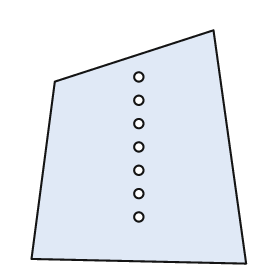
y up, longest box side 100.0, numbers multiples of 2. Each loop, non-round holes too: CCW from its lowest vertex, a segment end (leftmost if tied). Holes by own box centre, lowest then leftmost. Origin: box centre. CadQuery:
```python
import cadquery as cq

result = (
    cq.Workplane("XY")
    .moveTo(46.0, -50.0)
    .lineTo(32.0, 50.0)
    .lineTo(-36.0, 28.0)
    .lineTo(-46.0, -48.0)
    .close()
    .moveTo(0.0, -30.0)
    .circle(2.0)
    .moveTo(0.0, -20.0)
    .circle(2.0)
    .moveTo(0.0, -10.0)
    .circle(2.0)
    .moveTo(0.0, 0.0)
    .circle(2.0)
    .moveTo(0.0, 10.0)
    .circle(2.0)
    .moveTo(0.0, 20.0)
    .circle(2.0)
    .moveTo(0.0, 30.0)
    .circle(2.0)
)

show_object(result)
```